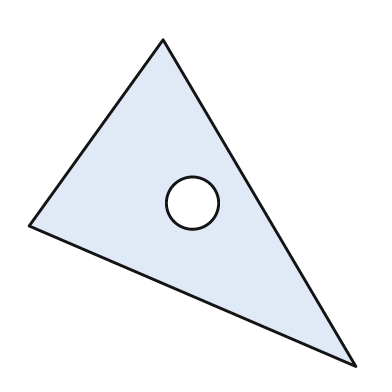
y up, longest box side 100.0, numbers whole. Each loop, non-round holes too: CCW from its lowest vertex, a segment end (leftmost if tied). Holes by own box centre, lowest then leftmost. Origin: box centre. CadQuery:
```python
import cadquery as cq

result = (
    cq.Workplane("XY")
    .moveTo(50.0, -50.0)
    .lineTo(-9.0, 50.0)
    .lineTo(-50.0, -7.0)
    .close()
    .moveTo(0.0, 0.0)
    .circle(8.0)
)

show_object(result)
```